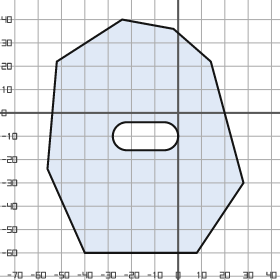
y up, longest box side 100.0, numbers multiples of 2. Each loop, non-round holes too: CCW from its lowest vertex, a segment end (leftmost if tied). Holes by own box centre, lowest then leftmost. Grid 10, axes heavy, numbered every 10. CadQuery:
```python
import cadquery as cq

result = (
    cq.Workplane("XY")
    .moveTo(-40.0, -60.0)
    .lineTo(8.0, -60.0)
    .lineTo(28.0, -30.0)
    .lineTo(14.0, 22.0)
    .lineTo(-2.0, 36.0)
    .lineTo(-24.0, 40.0)
    .lineTo(-52.0, 22.0)
    .lineTo(-56.0, -24.0)
    .close()
    .moveTo(-22.0, -16.0)
    .lineTo(-6.0, -16.0)
    .threePointArc((0.0, -10.0), (-6.0, -4.0))
    .lineTo(-22.0, -4.0)
    .threePointArc((-28.0, -10.0), (-22.0, -16.0))
    .close()
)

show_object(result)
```